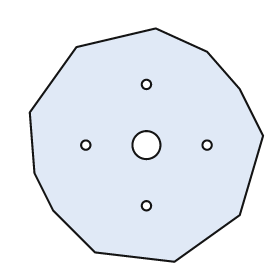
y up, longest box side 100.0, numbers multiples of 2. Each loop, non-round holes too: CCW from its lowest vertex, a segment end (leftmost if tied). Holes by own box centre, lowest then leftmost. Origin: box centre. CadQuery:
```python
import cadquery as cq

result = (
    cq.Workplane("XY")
    .moveTo(12.0, -50.0)
    .lineTo(40.0, -30.0)
    .lineTo(50.0, 4.0)
    .lineTo(40.0, 24.0)
    .lineTo(26.0, 40.0)
    .lineTo(4.0, 50.0)
    .lineTo(-30.0, 42.0)
    .lineTo(-50.0, 14.0)
    .lineTo(-48.0, -12.0)
    .lineTo(-40.0, -28.0)
    .lineTo(-22.0, -46.0)
    .close()
    .moveTo(0.0, -26.0)
    .circle(2.0)
    .moveTo(-26.0, 0.0)
    .circle(2.0)
    .moveTo(0.0, 0.0)
    .circle(6.0)
    .moveTo(26.0, 0.0)
    .circle(2.0)
    .moveTo(0.0, 26.0)
    .circle(2.0)
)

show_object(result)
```